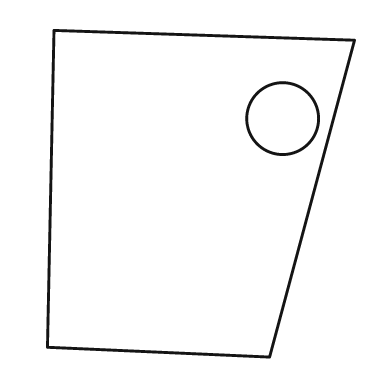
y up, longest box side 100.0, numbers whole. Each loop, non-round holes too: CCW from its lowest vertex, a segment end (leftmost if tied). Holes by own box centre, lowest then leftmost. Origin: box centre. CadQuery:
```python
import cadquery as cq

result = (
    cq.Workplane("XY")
    .moveTo(21.0, -50.0)
    .lineTo(47.0, 47.0)
    .lineTo(-45.0, 50.0)
    .lineTo(-47.0, -47.0)
    .close()
    .moveTo(25.0, 23.0)
    .circle(11.0)
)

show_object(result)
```